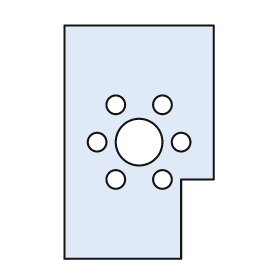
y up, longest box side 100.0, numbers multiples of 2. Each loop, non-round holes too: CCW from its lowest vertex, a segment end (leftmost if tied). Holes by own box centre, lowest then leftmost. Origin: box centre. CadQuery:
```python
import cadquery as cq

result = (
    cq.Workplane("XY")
    .moveTo(-32.0, -50.0)
    .lineTo(18.0, -50.0)
    .lineTo(18.0, -16.0)
    .lineTo(32.0, -16.0)
    .lineTo(32.0, 50.0)
    .lineTo(-32.0, 50.0)
    .close()
    .moveTo(-10.0, -16.0)
    .circle(4.0)
    .moveTo(10.0, -16.0)
    .circle(4.0)
    .moveTo(-18.0, 0.0)
    .circle(4.0)
    .moveTo(0.0, 0.0)
    .circle(10.0)
    .moveTo(18.0, 0.0)
    .circle(4.0)
    .moveTo(-10.0, 16.0)
    .circle(4.0)
    .moveTo(10.0, 16.0)
    .circle(4.0)
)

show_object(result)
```